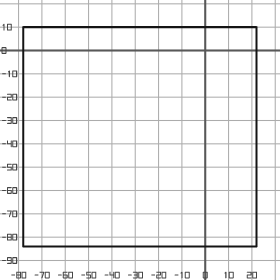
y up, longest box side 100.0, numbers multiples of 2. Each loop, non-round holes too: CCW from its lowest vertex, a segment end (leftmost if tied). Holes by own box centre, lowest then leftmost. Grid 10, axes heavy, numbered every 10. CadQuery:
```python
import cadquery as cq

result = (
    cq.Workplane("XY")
    .moveTo(-78.0, -84.0)
    .lineTo(22.0, -84.0)
    .lineTo(22.0, 10.0)
    .lineTo(-78.0, 10.0)
    .close()
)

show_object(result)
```